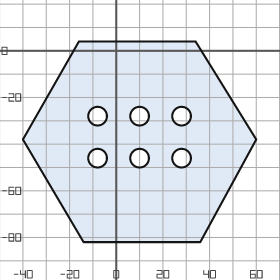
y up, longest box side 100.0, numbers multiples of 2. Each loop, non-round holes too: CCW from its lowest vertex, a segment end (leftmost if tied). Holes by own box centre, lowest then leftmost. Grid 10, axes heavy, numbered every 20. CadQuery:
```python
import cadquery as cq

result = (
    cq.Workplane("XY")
    .moveTo(-14.0, -82.0)
    .lineTo(36.0, -82.0)
    .lineTo(60.0, -38.0)
    .lineTo(34.0, 4.0)
    .lineTo(-16.0, 4.0)
    .lineTo(-40.0, -38.0)
    .close()
    .moveTo(-8.0, -46.0)
    .circle(4.0)
    .moveTo(10.0, -46.0)
    .circle(4.0)
    .moveTo(28.0, -46.0)
    .circle(4.0)
    .moveTo(-8.0, -28.0)
    .circle(4.0)
    .moveTo(10.0, -28.0)
    .circle(4.0)
    .moveTo(28.0, -28.0)
    .circle(4.0)
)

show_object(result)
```